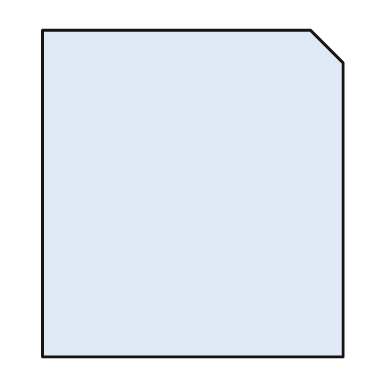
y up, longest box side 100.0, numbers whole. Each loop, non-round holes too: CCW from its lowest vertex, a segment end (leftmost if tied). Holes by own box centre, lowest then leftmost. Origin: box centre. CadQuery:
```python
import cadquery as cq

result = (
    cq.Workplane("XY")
    .moveTo(-46.0, -50.0)
    .lineTo(46.0, -50.0)
    .lineTo(46.0, 40.0)
    .lineTo(36.0, 50.0)
    .lineTo(-46.0, 50.0)
    .close()
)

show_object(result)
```